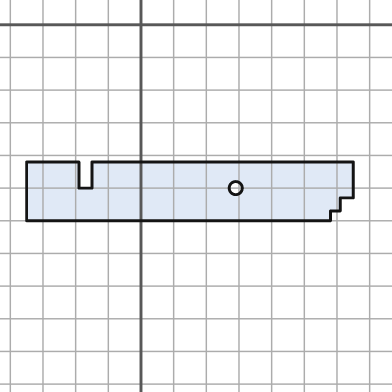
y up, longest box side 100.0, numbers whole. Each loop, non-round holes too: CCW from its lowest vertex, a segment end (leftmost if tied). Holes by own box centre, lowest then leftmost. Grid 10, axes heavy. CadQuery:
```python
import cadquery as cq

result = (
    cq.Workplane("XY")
    .moveTo(-35.0, -60.0)
    .lineTo(58.0, -60.0)
    .lineTo(58.0, -57.0)
    .lineTo(61.0, -57.0)
    .lineTo(61.0, -53.0)
    .lineTo(65.0, -53.0)
    .lineTo(65.0, -42.0)
    .lineTo(-15.0, -42.0)
    .lineTo(-15.0, -50.0)
    .lineTo(-19.0, -50.0)
    .lineTo(-19.0, -42.0)
    .lineTo(-35.0, -42.0)
    .close()
    .moveTo(29.0, -50.0)
    .circle(2.0)
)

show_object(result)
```